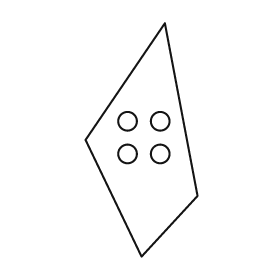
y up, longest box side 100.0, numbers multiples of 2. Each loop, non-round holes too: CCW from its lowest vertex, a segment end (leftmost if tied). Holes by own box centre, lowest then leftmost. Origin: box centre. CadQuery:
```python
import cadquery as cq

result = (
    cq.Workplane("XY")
    .moveTo(0.0, -50.0)
    .lineTo(24.0, -24.0)
    .lineTo(10.0, 50.0)
    .lineTo(-24.0, 0.0)
    .close()
    .moveTo(-6.0, -6.0)
    .circle(4.0)
    .moveTo(8.0, -6.0)
    .circle(4.0)
    .moveTo(-6.0, 8.0)
    .circle(4.0)
    .moveTo(8.0, 8.0)
    .circle(4.0)
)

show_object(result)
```